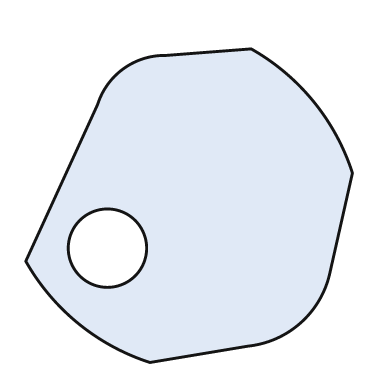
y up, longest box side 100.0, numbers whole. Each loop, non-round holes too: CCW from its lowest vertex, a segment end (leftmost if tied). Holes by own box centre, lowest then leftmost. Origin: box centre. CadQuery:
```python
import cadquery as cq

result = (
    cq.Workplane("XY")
    .moveTo(-12.0, -48.0)
    .lineTo(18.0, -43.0)
    .threePointArc((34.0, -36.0), (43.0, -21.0))
    .lineTo(50.0, 10.0)
    .threePointArc((38.0, 32.0), (19.0, 48.0))
    .lineTo(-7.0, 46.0)
    .threePointArc((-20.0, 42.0), (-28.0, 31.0))
    .lineTo(-50.0, -17.0)
    .threePointArc((-34.0, -36.0), (-12.0, -48.0))
    .close()
    .moveTo(-25.0, -13.0)
    .circle(12.0)
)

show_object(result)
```